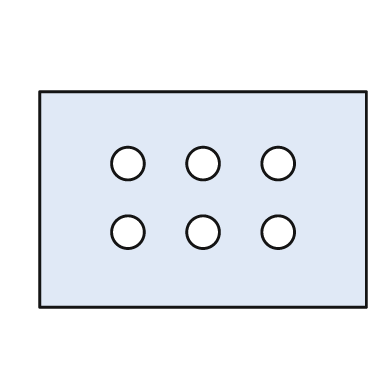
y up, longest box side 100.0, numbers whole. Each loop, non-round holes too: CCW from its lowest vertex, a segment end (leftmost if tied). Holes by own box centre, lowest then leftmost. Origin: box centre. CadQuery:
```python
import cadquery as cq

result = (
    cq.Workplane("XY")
    .moveTo(-50.0, -33.0)
    .lineTo(50.0, -33.0)
    .lineTo(50.0, 33.0)
    .lineTo(-50.0, 33.0)
    .close()
    .moveTo(-23.0, -10.0)
    .circle(5.0)
    .moveTo(0.0, -10.0)
    .circle(5.0)
    .moveTo(23.0, -10.0)
    .circle(5.0)
    .moveTo(-23.0, 11.0)
    .circle(5.0)
    .moveTo(0.0, 11.0)
    .circle(5.0)
    .moveTo(23.0, 11.0)
    .circle(5.0)
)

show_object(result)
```